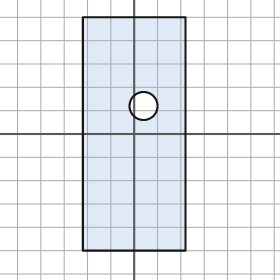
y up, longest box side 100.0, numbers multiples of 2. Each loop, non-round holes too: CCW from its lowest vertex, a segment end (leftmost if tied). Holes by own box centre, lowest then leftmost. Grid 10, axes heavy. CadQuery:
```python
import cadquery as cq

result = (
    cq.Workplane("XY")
    .moveTo(-22.0, -50.0)
    .lineTo(22.0, -50.0)
    .lineTo(22.0, 50.0)
    .lineTo(-22.0, 50.0)
    .close()
    .moveTo(4.0, 12.0)
    .circle(6.0)
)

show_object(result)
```